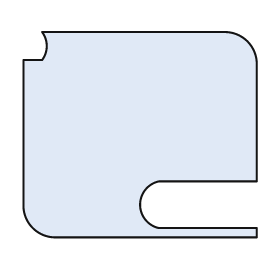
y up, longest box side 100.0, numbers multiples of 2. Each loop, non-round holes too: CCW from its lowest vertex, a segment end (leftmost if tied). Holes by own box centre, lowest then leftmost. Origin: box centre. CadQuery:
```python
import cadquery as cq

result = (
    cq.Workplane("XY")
    .moveTo(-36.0, -44.0)
    .lineTo(50.0, -44.0)
    .lineTo(50.0, -40.0)
    .lineTo(8.0, -40.0)
    .threePointArc((0.0, -30.0), (8.0, -20.0))
    .lineTo(50.0, -20.0)
    .lineTo(50.0, 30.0)
    .threePointArc((46.0, 40.0), (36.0, 44.0))
    .lineTo(-42.0, 44.0)
    .threePointArc((-40.0, 38.0), (-42.0, 32.0))
    .lineTo(-50.0, 32.0)
    .lineTo(-50.0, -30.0)
    .threePointArc((-46.0, -40.0), (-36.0, -44.0))
    .close()
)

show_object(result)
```